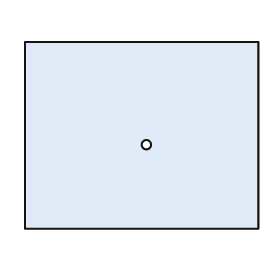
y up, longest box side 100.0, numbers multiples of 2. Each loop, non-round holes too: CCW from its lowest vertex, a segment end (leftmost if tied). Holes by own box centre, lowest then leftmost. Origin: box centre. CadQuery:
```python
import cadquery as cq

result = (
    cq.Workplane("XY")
    .moveTo(-50.0, -40.0)
    .lineTo(50.0, -40.0)
    .lineTo(50.0, 40.0)
    .lineTo(-50.0, 40.0)
    .close()
    .moveTo(2.0, -4.0)
    .circle(2.0)
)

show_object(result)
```